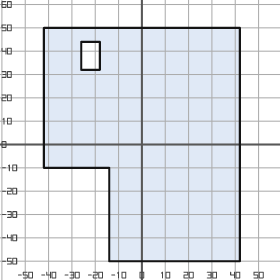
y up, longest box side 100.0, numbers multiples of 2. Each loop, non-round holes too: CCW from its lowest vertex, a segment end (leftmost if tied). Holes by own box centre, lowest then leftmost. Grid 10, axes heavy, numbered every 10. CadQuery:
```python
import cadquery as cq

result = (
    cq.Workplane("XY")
    .moveTo(-14.0, -50.0)
    .lineTo(42.0, -50.0)
    .lineTo(42.0, 50.0)
    .lineTo(-42.0, 50.0)
    .lineTo(-42.0, -10.0)
    .lineTo(-14.0, -10.0)
    .close()
    .moveTo(-26.0, 32.0)
    .lineTo(-18.0, 32.0)
    .lineTo(-18.0, 44.0)
    .lineTo(-26.0, 44.0)
    .close()
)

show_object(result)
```